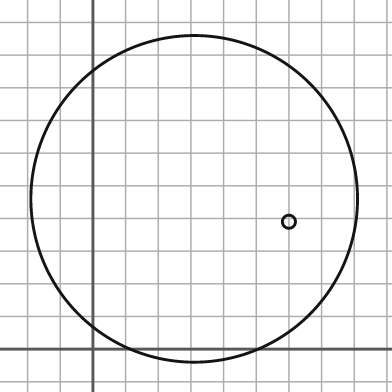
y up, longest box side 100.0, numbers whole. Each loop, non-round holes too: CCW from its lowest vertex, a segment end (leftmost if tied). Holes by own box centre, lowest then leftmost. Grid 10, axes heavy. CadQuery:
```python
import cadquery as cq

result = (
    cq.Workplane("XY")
    .moveTo(31.0, 46.0)
    .circle(50.0)
    .moveTo(60.0, 39.0)
    .circle(2.0)
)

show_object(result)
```